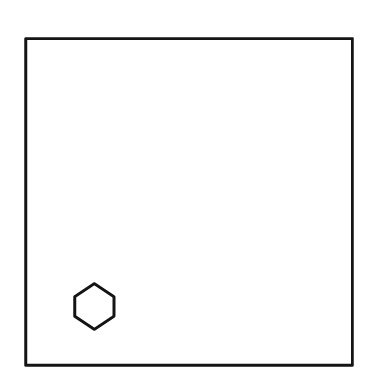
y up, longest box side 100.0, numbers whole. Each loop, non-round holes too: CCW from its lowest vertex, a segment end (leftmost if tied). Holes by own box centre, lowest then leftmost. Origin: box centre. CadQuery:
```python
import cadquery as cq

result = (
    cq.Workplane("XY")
    .moveTo(-50.0, -50.0)
    .lineTo(50.0, -50.0)
    .lineTo(50.0, 50.0)
    .lineTo(-50.0, 50.0)
    .close()
    .moveTo(-29.0, -39.0)
    .lineTo(-23.0, -35.0)
    .lineTo(-23.0, -29.0)
    .lineTo(-29.0, -25.0)
    .lineTo(-35.0, -29.0)
    .lineTo(-35.0, -35.0)
    .close()
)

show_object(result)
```